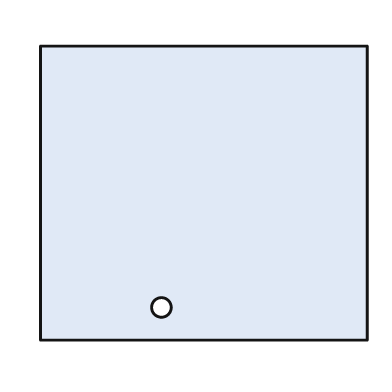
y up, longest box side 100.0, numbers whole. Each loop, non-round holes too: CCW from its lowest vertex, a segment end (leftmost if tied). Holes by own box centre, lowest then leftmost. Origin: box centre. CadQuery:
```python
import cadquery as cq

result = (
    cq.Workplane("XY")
    .moveTo(-50.0, -45.0)
    .lineTo(50.0, -45.0)
    .lineTo(50.0, 45.0)
    .lineTo(-50.0, 45.0)
    .close()
    .moveTo(-13.0, -35.0)
    .circle(3.0)
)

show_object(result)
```